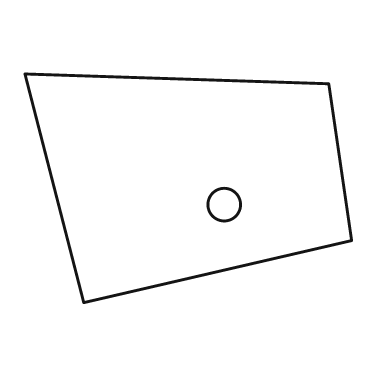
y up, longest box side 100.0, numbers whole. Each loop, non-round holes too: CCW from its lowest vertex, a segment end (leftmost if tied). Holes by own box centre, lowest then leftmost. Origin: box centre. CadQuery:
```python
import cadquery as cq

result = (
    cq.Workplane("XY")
    .moveTo(-32.0, -35.0)
    .lineTo(50.0, -16.0)
    .lineTo(43.0, 32.0)
    .lineTo(-50.0, 35.0)
    .close()
    .moveTo(11.0, -5.0)
    .circle(5.0)
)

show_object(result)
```